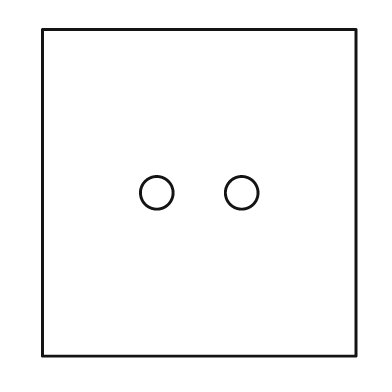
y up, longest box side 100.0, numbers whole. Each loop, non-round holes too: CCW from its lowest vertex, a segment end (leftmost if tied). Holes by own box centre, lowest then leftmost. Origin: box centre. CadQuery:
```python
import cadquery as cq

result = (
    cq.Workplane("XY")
    .moveTo(-48.0, -50.0)
    .lineTo(48.0, -50.0)
    .lineTo(48.0, 50.0)
    .lineTo(-48.0, 50.0)
    .close()
    .moveTo(-13.0, 0.0)
    .circle(5.0)
    .moveTo(13.0, 0.0)
    .circle(5.0)
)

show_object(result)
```